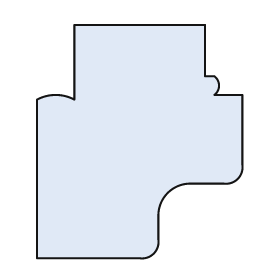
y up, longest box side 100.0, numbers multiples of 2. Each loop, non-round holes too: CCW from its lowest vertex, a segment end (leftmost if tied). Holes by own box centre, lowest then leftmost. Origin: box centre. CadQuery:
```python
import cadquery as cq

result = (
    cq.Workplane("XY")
    .moveTo(-44.0, -50.0)
    .lineTo(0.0, -50.0)
    .threePointArc((6.0, -48.0), (8.0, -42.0))
    .lineTo(8.0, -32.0)
    .threePointArc((12.0, -22.0), (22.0, -18.0))
    .lineTo(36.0, -18.0)
    .threePointArc((42.0, -16.0), (44.0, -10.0))
    .lineTo(44.0, 20.0)
    .lineTo(32.0, 20.0)
    .threePointArc((34.0, 24.0), (32.0, 28.0))
    .lineTo(28.0, 28.0)
    .lineTo(28.0, 50.0)
    .lineTo(-28.0, 50.0)
    .lineTo(-28.0, 18.0)
    .threePointArc((-36.0, 20.0), (-44.0, 18.0))
    .close()
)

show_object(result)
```